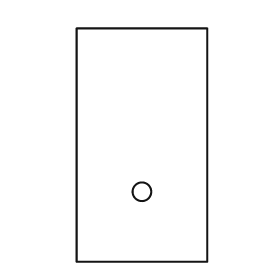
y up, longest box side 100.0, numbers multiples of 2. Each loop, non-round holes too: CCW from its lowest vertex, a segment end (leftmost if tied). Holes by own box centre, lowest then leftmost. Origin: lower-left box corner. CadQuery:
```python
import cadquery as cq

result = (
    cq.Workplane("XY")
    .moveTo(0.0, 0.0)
    .lineTo(56.0, 0.0)
    .lineTo(56.0, 100.0)
    .lineTo(0.0, 100.0)
    .close()
    .moveTo(28.0, 30.0)
    .circle(4.0)
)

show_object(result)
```